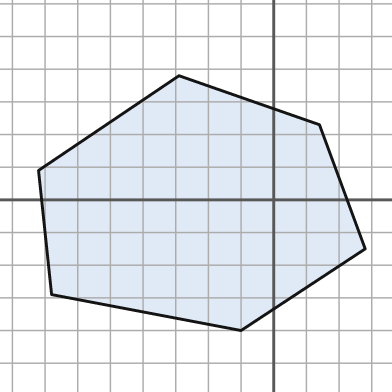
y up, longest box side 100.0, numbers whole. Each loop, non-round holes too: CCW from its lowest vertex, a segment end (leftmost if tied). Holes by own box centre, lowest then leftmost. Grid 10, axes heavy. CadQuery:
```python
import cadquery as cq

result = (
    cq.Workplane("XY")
    .moveTo(-10.0, -40.0)
    .lineTo(28.0, -15.0)
    .lineTo(14.0, 23.0)
    .lineTo(-29.0, 38.0)
    .lineTo(-72.0, 9.0)
    .lineTo(-68.0, -29.0)
    .close()
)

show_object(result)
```